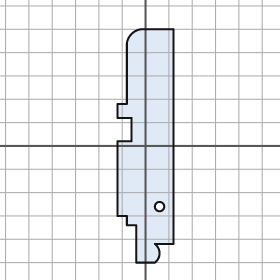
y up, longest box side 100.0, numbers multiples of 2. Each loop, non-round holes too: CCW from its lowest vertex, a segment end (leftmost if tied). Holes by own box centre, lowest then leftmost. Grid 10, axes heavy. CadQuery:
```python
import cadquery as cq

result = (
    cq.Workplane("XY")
    .moveTo(-4.0, -50.0)
    .lineTo(4.0, -50.0)
    .threePointArc((6.0, -46.0), (4.0, -42.0))
    .lineTo(12.0, -42.0)
    .lineTo(12.0, 50.0)
    .lineTo(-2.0, 50.0)
    .threePointArc((-6.0, 48.0), (-8.0, 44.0))
    .lineTo(-8.0, 18.0)
    .lineTo(-12.0, 18.0)
    .lineTo(-12.0, 12.0)
    .lineTo(-6.0, 12.0)
    .lineTo(-6.0, 2.0)
    .lineTo(-12.0, 2.0)
    .lineTo(-12.0, -30.0)
    .lineTo(-8.0, -30.0)
    .lineTo(-8.0, -34.0)
    .lineTo(-4.0, -34.0)
    .close()
    .moveTo(6.0, -26.0)
    .circle(2.0)
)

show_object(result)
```